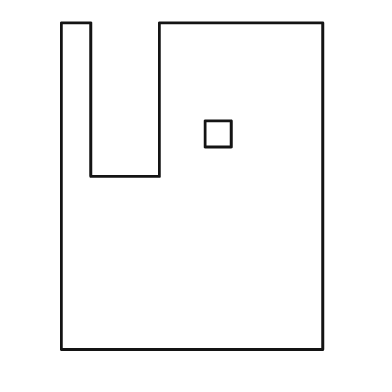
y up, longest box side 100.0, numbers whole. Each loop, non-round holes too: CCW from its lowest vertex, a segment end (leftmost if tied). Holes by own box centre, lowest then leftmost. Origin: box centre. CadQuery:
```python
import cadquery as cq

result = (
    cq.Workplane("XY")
    .moveTo(-40.0, -50.0)
    .lineTo(40.0, -50.0)
    .lineTo(40.0, 50.0)
    .lineTo(-10.0, 50.0)
    .lineTo(-10.0, 3.0)
    .lineTo(-31.0, 3.0)
    .lineTo(-31.0, 50.0)
    .lineTo(-40.0, 50.0)
    .close()
    .moveTo(4.0, 12.0)
    .lineTo(12.0, 12.0)
    .lineTo(12.0, 20.0)
    .lineTo(4.0, 20.0)
    .close()
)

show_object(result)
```